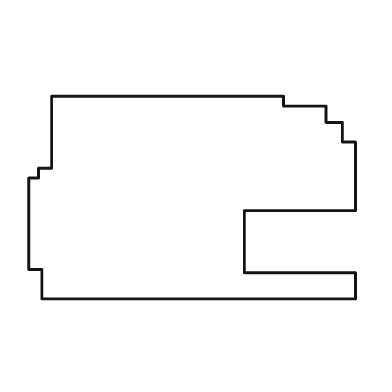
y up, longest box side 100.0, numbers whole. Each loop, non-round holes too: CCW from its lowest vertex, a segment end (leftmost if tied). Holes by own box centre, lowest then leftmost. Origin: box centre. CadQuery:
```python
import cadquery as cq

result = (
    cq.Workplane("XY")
    .moveTo(-46.0, -31.0)
    .lineTo(50.0, -31.0)
    .lineTo(50.0, -23.0)
    .lineTo(16.0, -23.0)
    .lineTo(16.0, -4.0)
    .lineTo(50.0, -4.0)
    .lineTo(50.0, 17.0)
    .lineTo(46.0, 17.0)
    .lineTo(46.0, 23.0)
    .lineTo(41.0, 23.0)
    .lineTo(41.0, 28.0)
    .lineTo(28.0, 28.0)
    .lineTo(28.0, 31.0)
    .lineTo(-43.0, 31.0)
    .lineTo(-43.0, 9.0)
    .lineTo(-47.0, 9.0)
    .lineTo(-47.0, 6.0)
    .lineTo(-50.0, 6.0)
    .lineTo(-50.0, -22.0)
    .lineTo(-46.0, -22.0)
    .close()
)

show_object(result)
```